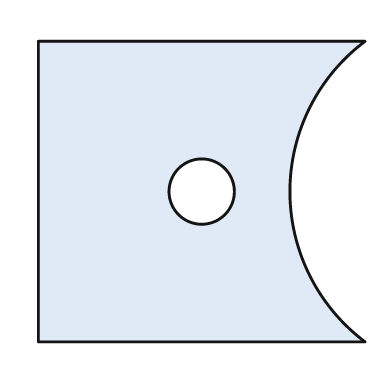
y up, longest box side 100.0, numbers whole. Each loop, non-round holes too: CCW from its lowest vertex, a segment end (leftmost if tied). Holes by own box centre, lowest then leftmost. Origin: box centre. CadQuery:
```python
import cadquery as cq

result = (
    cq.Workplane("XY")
    .moveTo(-50.0, -46.0)
    .lineTo(50.0, -46.0)
    .threePointArc((27.0, 0.0), (50.0, 46.0))
    .lineTo(-50.0, 46.0)
    .close()
    .moveTo(0.0, 0.0)
    .circle(10.0)
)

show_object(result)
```